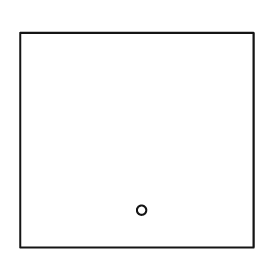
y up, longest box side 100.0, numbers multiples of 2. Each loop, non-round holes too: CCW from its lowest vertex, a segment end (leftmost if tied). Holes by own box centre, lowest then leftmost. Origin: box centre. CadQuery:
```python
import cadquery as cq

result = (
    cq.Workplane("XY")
    .moveTo(-50.0, -46.0)
    .lineTo(50.0, -46.0)
    .lineTo(50.0, 46.0)
    .lineTo(-50.0, 46.0)
    .close()
    .moveTo(2.0, -30.0)
    .circle(2.0)
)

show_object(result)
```